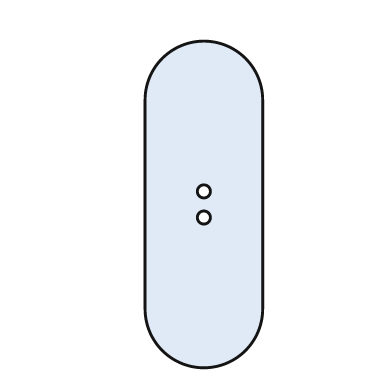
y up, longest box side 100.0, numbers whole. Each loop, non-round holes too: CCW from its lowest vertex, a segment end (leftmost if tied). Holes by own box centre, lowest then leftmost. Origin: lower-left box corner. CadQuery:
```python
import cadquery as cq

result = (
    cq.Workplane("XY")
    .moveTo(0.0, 18.0)
    .threePointArc((18.0, 0.0), (36.0, 18.0))
    .lineTo(36.0, 82.0)
    .threePointArc((18.0, 100.0), (0.0, 82.0))
    .close()
    .moveTo(18.0, 46.0)
    .circle(2.0)
    .moveTo(18.0, 54.0)
    .circle(2.0)
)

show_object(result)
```